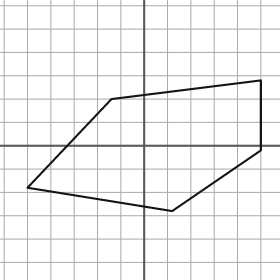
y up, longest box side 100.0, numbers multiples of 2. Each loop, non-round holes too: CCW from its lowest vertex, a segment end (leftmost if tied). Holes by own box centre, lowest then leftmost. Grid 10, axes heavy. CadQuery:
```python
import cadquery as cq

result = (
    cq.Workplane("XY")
    .moveTo(12.0, -28.0)
    .lineTo(50.0, -2.0)
    .lineTo(50.0, 28.0)
    .lineTo(-14.0, 20.0)
    .lineTo(-50.0, -18.0)
    .close()
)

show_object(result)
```